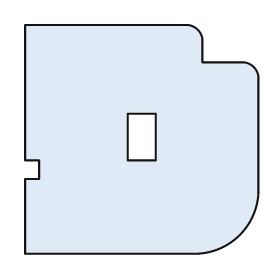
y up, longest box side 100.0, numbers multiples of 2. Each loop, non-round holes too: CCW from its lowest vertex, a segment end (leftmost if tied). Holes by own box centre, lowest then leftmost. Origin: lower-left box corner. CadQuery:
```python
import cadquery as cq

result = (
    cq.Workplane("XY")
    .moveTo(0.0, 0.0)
    .lineTo(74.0, 0.0)
    .threePointArc((92.0, 8.0), (100.0, 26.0))
    .lineTo(100.0, 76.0)
    .threePointArc((98.0, 80.0), (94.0, 82.0))
    .lineTo(76.0, 82.0)
    .lineTo(76.0, 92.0)
    .threePointArc((74.0, 96.0), (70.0, 98.0))
    .lineTo(0.0, 98.0)
    .lineTo(0.0, 40.0)
    .lineTo(6.0, 40.0)
    .lineTo(6.0, 32.0)
    .lineTo(0.0, 32.0)
    .close()
    .moveTo(44.0, 40.0)
    .lineTo(56.0, 40.0)
    .lineTo(56.0, 60.0)
    .lineTo(44.0, 60.0)
    .close()
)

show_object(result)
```